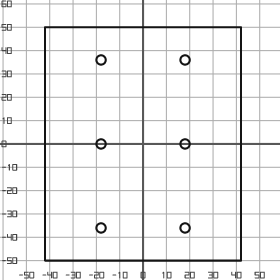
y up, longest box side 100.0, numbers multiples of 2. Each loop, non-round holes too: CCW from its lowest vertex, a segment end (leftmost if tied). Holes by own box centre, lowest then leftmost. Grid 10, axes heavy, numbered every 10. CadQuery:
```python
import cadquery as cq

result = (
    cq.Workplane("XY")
    .moveTo(-42.0, -50.0)
    .lineTo(42.0, -50.0)
    .lineTo(42.0, 50.0)
    .lineTo(-42.0, 50.0)
    .close()
    .moveTo(-18.0, -36.0)
    .circle(2.0)
    .moveTo(18.0, -36.0)
    .circle(2.0)
    .moveTo(-18.0, 0.0)
    .circle(2.0)
    .moveTo(18.0, 0.0)
    .circle(2.0)
    .moveTo(-18.0, 36.0)
    .circle(2.0)
    .moveTo(18.0, 36.0)
    .circle(2.0)
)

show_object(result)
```